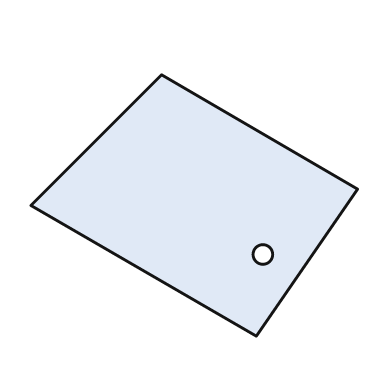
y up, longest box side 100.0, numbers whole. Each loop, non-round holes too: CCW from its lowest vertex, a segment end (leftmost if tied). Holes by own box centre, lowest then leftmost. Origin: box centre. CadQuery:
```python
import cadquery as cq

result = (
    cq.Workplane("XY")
    .moveTo(19.0, -40.0)
    .lineTo(50.0, 5.0)
    .lineTo(-10.0, 40.0)
    .lineTo(-50.0, 0.0)
    .close()
    .moveTo(21.0, -15.0)
    .circle(3.0)
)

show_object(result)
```